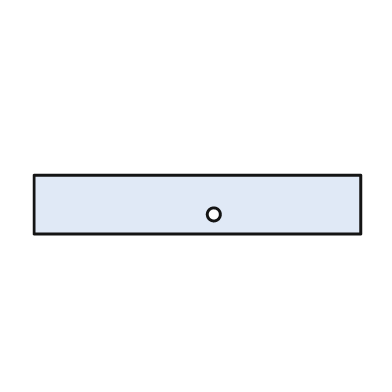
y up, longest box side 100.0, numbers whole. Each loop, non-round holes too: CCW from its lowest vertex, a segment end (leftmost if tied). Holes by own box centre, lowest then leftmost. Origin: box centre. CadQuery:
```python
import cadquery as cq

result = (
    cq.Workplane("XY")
    .moveTo(-50.0, -9.0)
    .lineTo(50.0, -9.0)
    .lineTo(50.0, 9.0)
    .lineTo(-50.0, 9.0)
    .close()
    .moveTo(5.0, -3.0)
    .circle(2.0)
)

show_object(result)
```